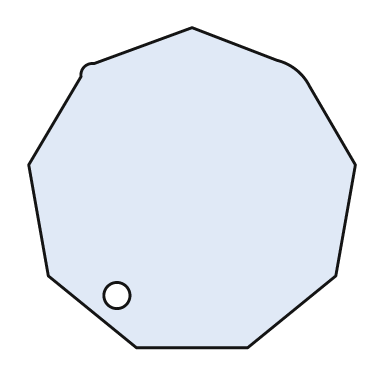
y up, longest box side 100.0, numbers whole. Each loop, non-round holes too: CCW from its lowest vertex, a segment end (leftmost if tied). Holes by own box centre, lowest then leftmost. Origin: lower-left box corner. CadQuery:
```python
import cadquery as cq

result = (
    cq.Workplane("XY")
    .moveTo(33.0, 0.0)
    .lineTo(67.0, 0.0)
    .lineTo(94.0, 22.0)
    .lineTo(100.0, 56.0)
    .lineTo(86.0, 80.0)
    .threePointArc((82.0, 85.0), (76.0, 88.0))
    .lineTo(50.0, 98.0)
    .lineTo(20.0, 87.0)
    .threePointArc((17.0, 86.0), (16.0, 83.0))
    .lineTo(0.0, 56.0)
    .lineTo(6.0, 22.0)
    .close()
    .moveTo(27.0, 16.0)
    .circle(4.0)
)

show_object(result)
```